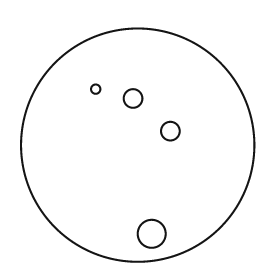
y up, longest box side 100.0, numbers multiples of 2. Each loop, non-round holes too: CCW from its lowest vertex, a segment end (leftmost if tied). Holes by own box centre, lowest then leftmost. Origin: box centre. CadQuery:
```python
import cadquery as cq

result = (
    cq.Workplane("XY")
    .moveTo(0.0, 0.0)
    .circle(50.0)
    .moveTo(6.0, -38.0)
    .circle(6.0)
    .moveTo(14.0, 6.0)
    .circle(4.0)
    .moveTo(-2.0, 20.0)
    .circle(4.0)
    .moveTo(-18.0, 24.0)
    .circle(2.0)
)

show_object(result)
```